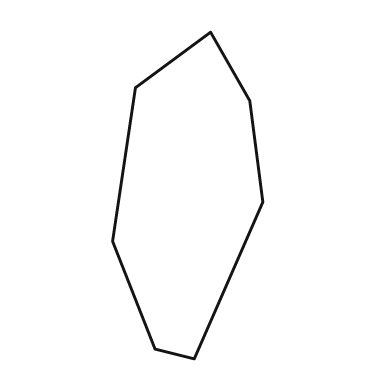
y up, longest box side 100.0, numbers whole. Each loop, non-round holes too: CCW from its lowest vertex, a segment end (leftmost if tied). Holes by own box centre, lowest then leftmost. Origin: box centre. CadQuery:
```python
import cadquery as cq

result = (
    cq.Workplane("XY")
    .moveTo(2.0, -50.0)
    .lineTo(23.0, -2.0)
    .lineTo(19.0, 29.0)
    .lineTo(7.0, 50.0)
    .lineTo(-16.0, 33.0)
    .lineTo(-23.0, -14.0)
    .lineTo(-10.0, -47.0)
    .close()
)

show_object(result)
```